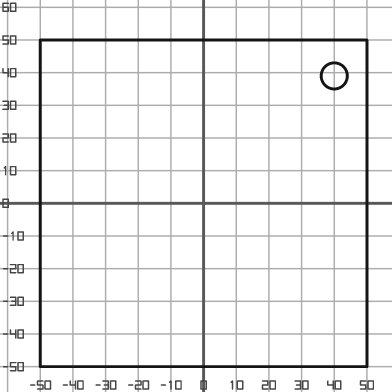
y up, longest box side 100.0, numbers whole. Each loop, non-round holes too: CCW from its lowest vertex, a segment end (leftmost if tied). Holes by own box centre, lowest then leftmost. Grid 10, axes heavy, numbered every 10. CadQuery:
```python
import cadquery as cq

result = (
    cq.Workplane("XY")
    .moveTo(-50.0, -50.0)
    .lineTo(50.0, -50.0)
    .lineTo(50.0, 50.0)
    .lineTo(-50.0, 50.0)
    .close()
    .moveTo(40.0, 39.0)
    .circle(4.0)
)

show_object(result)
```